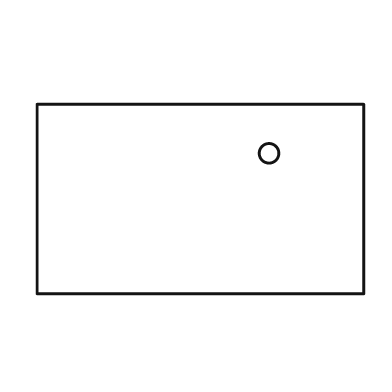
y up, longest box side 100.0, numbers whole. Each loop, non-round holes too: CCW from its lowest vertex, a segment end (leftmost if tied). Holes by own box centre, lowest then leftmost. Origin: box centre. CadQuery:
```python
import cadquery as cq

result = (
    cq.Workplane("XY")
    .moveTo(-50.0, -29.0)
    .lineTo(50.0, -29.0)
    .lineTo(50.0, 29.0)
    .lineTo(-50.0, 29.0)
    .close()
    .moveTo(21.0, 14.0)
    .circle(3.0)
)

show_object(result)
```